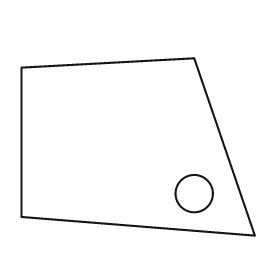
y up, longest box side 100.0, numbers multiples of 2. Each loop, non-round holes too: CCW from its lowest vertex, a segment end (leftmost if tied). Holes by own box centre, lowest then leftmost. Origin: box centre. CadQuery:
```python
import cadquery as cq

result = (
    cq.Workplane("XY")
    .moveTo(50.0, -38.0)
    .lineTo(24.0, 38.0)
    .lineTo(-50.0, 34.0)
    .lineTo(-50.0, -30.0)
    .close()
    .moveTo(24.0, -20.0)
    .circle(8.0)
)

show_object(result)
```